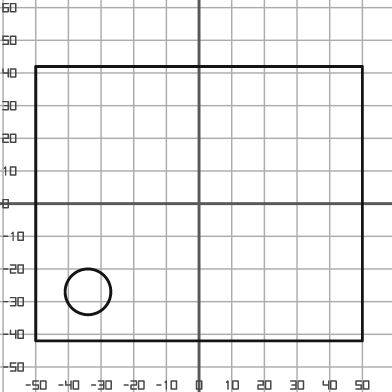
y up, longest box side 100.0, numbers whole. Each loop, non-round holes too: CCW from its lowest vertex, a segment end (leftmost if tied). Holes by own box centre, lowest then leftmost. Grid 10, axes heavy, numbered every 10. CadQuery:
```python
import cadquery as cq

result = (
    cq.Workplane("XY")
    .moveTo(-50.0, -42.0)
    .lineTo(50.0, -42.0)
    .lineTo(50.0, 42.0)
    .lineTo(-50.0, 42.0)
    .close()
    .moveTo(-34.0, -27.0)
    .circle(7.0)
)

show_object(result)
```